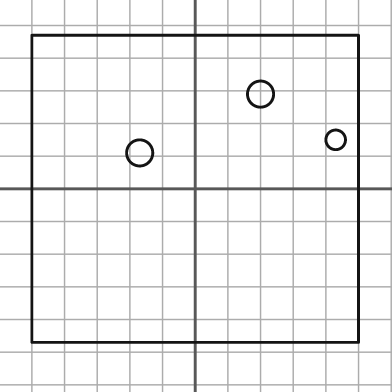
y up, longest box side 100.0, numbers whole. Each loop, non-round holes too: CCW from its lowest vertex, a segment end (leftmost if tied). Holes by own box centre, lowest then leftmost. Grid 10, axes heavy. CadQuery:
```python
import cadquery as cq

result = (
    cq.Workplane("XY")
    .moveTo(-50.0, -47.0)
    .lineTo(50.0, -47.0)
    .lineTo(50.0, 47.0)
    .lineTo(-50.0, 47.0)
    .close()
    .moveTo(-17.0, 11.0)
    .circle(4.0)
    .moveTo(43.0, 15.0)
    .circle(3.0)
    .moveTo(20.0, 29.0)
    .circle(4.0)
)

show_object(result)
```